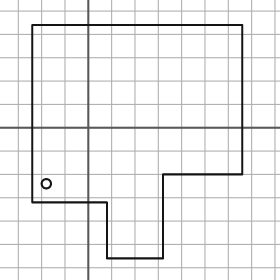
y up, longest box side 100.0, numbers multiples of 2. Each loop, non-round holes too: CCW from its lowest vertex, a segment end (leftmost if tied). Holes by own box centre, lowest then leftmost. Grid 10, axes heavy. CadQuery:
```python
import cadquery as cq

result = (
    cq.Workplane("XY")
    .moveTo(8.0, -56.0)
    .lineTo(32.0, -56.0)
    .lineTo(32.0, -20.0)
    .lineTo(66.0, -20.0)
    .lineTo(66.0, 44.0)
    .lineTo(-24.0, 44.0)
    .lineTo(-24.0, -32.0)
    .lineTo(8.0, -32.0)
    .close()
    .moveTo(-18.0, -24.0)
    .circle(2.0)
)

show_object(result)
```